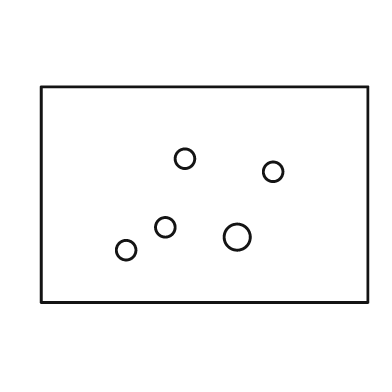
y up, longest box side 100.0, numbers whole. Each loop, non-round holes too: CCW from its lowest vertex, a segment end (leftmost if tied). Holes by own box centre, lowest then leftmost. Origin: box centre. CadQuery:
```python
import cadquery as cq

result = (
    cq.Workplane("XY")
    .moveTo(-50.0, -33.0)
    .lineTo(50.0, -33.0)
    .lineTo(50.0, 33.0)
    .lineTo(-50.0, 33.0)
    .close()
    .moveTo(-24.0, -17.0)
    .circle(3.0)
    .moveTo(10.0, -13.0)
    .circle(4.0)
    .moveTo(-12.0, -10.0)
    .circle(3.0)
    .moveTo(21.0, 7.0)
    .circle(3.0)
    .moveTo(-6.0, 11.0)
    .circle(3.0)
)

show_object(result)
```